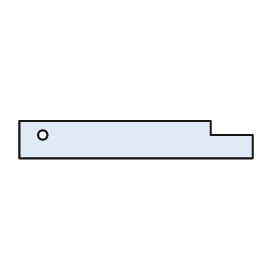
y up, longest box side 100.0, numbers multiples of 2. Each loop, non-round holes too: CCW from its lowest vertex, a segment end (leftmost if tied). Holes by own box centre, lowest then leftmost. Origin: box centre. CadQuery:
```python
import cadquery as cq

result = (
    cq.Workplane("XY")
    .moveTo(-50.0, -8.0)
    .lineTo(50.0, -8.0)
    .lineTo(50.0, 2.0)
    .lineTo(32.0, 2.0)
    .lineTo(32.0, 8.0)
    .lineTo(-50.0, 8.0)
    .close()
    .moveTo(-40.0, 2.0)
    .circle(2.0)
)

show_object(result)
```